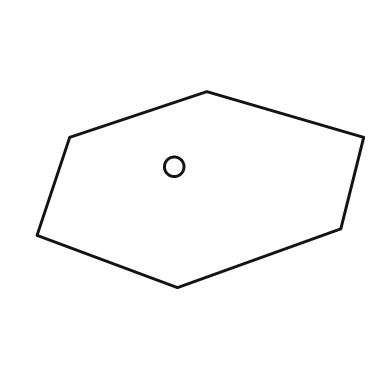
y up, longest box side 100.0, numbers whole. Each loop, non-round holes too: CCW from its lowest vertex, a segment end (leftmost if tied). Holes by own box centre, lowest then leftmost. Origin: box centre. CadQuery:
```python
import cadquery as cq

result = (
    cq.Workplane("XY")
    .moveTo(-7.0, -30.0)
    .lineTo(43.0, -12.0)
    .lineTo(50.0, 16.0)
    .lineTo(2.0, 30.0)
    .lineTo(-40.0, 16.0)
    .lineTo(-50.0, -14.0)
    .close()
    .moveTo(-8.0, 7.0)
    .circle(3.0)
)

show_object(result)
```